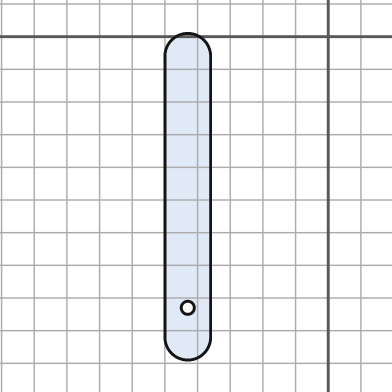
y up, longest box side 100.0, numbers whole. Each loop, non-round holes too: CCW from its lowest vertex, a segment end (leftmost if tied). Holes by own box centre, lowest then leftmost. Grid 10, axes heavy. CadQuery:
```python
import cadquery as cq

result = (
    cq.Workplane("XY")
    .moveTo(-50.0, -92.0)
    .threePointArc((-43.0, -99.0), (-36.0, -92.0))
    .lineTo(-36.0, -6.0)
    .threePointArc((-43.0, 1.0), (-50.0, -6.0))
    .close()
    .moveTo(-43.0, -83.0)
    .circle(2.0)
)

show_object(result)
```